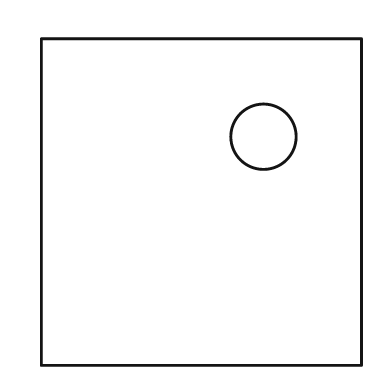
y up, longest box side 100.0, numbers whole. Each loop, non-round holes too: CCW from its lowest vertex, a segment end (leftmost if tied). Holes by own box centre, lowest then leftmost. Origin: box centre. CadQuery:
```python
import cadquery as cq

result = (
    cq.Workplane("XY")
    .moveTo(-49.0, -50.0)
    .lineTo(49.0, -50.0)
    .lineTo(49.0, 50.0)
    .lineTo(-49.0, 50.0)
    .close()
    .moveTo(19.0, 20.0)
    .circle(10.0)
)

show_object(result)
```